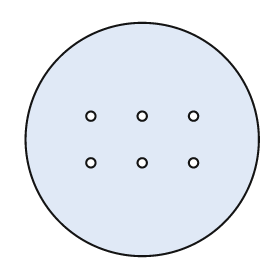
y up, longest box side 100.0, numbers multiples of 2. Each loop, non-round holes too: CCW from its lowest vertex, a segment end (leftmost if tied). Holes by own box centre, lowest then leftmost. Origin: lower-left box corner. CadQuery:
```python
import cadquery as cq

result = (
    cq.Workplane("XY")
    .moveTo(50.0, 50.0)
    .circle(50.0)
    .moveTo(28.0, 40.0)
    .circle(2.0)
    .moveTo(50.0, 40.0)
    .circle(2.0)
    .moveTo(72.0, 40.0)
    .circle(2.0)
    .moveTo(28.0, 60.0)
    .circle(2.0)
    .moveTo(50.0, 60.0)
    .circle(2.0)
    .moveTo(72.0, 60.0)
    .circle(2.0)
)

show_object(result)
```